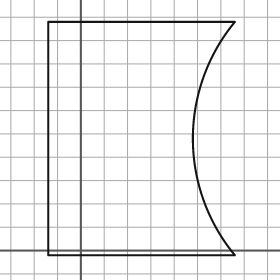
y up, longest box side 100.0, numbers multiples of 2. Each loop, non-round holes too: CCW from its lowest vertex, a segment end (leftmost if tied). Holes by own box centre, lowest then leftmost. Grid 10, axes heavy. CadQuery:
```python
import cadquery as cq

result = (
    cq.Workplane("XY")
    .moveTo(-14.0, -2.0)
    .lineTo(66.0, -2.0)
    .threePointArc((48.0, 48.0), (66.0, 98.0))
    .lineTo(-14.0, 98.0)
    .close()
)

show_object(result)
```